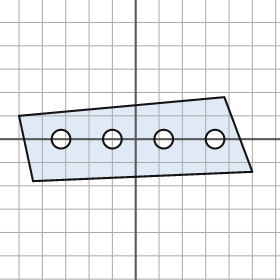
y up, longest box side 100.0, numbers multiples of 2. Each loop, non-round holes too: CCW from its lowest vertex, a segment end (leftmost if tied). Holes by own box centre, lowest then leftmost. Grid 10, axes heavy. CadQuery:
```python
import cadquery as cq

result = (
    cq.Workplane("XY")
    .moveTo(-44.0, -18.0)
    .lineTo(50.0, -14.0)
    .lineTo(38.0, 18.0)
    .lineTo(-50.0, 10.0)
    .close()
    .moveTo(-32.0, 0.0)
    .circle(4.0)
    .moveTo(-10.0, 0.0)
    .circle(4.0)
    .moveTo(12.0, 0.0)
    .circle(4.0)
    .moveTo(34.0, 0.0)
    .circle(4.0)
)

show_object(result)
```